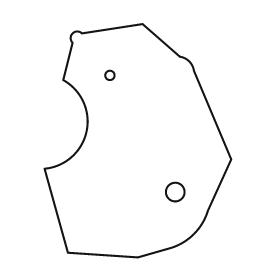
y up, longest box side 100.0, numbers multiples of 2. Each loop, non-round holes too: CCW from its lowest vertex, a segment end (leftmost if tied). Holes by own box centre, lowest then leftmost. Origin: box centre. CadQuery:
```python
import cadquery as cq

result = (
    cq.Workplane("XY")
    .moveTo(0.0, -50.0)
    .lineTo(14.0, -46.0)
    .threePointArc((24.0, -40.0), (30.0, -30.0))
    .lineTo(40.0, -8.0)
    .lineTo(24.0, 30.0)
    .threePointArc((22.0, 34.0), (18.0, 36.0))
    .lineTo(2.0, 50.0)
    .lineTo(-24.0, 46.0)
    .threePointArc((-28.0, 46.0), (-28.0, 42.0))
    .lineTo(-32.0, 26.0)
    .threePointArc((-22.0, 4.0), (-40.0, -12.0))
    .lineTo(-30.0, -48.0)
    .close()
    .moveTo(16.0, -22.0)
    .circle(4.0)
    .moveTo(-12.0, 28.0)
    .circle(2.0)
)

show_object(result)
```